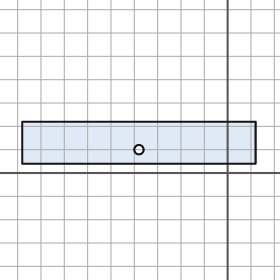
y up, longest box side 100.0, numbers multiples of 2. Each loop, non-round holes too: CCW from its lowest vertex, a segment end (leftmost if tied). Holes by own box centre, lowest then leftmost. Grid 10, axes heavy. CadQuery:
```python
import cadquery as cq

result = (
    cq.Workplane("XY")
    .moveTo(-88.0, 4.0)
    .lineTo(12.0, 4.0)
    .lineTo(12.0, 22.0)
    .lineTo(-88.0, 22.0)
    .close()
    .moveTo(-38.0, 10.0)
    .circle(2.0)
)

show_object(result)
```